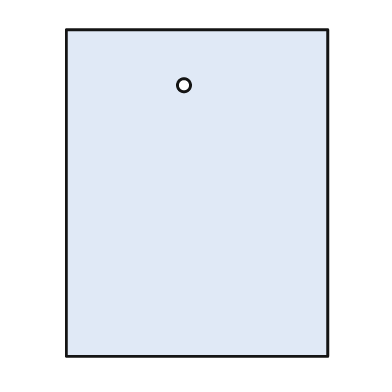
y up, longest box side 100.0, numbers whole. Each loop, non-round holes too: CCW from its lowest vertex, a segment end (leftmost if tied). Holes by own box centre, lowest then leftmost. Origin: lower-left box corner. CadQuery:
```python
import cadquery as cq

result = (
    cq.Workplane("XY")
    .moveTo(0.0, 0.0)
    .lineTo(80.0, 0.0)
    .lineTo(80.0, 100.0)
    .lineTo(0.0, 100.0)
    .close()
    .moveTo(36.0, 83.0)
    .circle(2.0)
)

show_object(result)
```